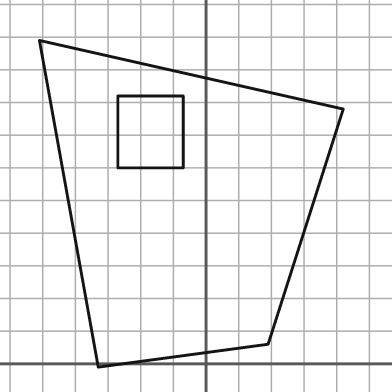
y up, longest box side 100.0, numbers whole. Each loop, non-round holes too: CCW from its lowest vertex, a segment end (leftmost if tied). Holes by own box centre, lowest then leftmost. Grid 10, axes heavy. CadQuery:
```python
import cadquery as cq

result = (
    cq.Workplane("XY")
    .moveTo(-33.0, -1.0)
    .lineTo(19.0, 6.0)
    .lineTo(42.0, 78.0)
    .lineTo(-51.0, 99.0)
    .close()
    .moveTo(-27.0, 60.0)
    .lineTo(-7.0, 60.0)
    .lineTo(-7.0, 82.0)
    .lineTo(-27.0, 82.0)
    .close()
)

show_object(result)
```